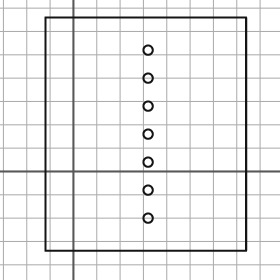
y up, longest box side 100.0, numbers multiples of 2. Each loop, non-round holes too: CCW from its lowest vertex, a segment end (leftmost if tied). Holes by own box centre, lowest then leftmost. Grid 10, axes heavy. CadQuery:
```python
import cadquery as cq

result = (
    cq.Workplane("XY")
    .moveTo(-12.0, -34.0)
    .lineTo(74.0, -34.0)
    .lineTo(74.0, 66.0)
    .lineTo(-12.0, 66.0)
    .close()
    .moveTo(32.0, -20.0)
    .circle(2.0)
    .moveTo(32.0, -8.0)
    .circle(2.0)
    .moveTo(32.0, 4.0)
    .circle(2.0)
    .moveTo(32.0, 16.0)
    .circle(2.0)
    .moveTo(32.0, 28.0)
    .circle(2.0)
    .moveTo(32.0, 40.0)
    .circle(2.0)
    .moveTo(32.0, 52.0)
    .circle(2.0)
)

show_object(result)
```